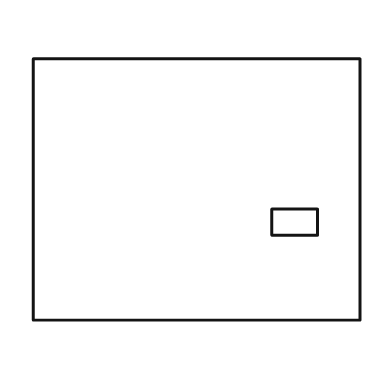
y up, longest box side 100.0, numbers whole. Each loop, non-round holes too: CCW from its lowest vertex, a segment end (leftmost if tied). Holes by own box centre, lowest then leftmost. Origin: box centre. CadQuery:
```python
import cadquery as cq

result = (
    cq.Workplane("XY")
    .moveTo(-50.0, -40.0)
    .lineTo(50.0, -40.0)
    .lineTo(50.0, 40.0)
    .lineTo(-50.0, 40.0)
    .close()
    .moveTo(23.0, -14.0)
    .lineTo(37.0, -14.0)
    .lineTo(37.0, -6.0)
    .lineTo(23.0, -6.0)
    .close()
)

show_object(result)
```